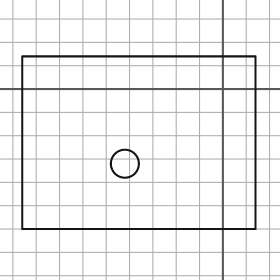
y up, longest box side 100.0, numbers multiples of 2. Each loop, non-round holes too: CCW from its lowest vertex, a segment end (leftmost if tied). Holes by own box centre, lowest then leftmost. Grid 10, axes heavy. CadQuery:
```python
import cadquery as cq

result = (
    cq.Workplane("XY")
    .moveTo(-86.0, -60.0)
    .lineTo(14.0, -60.0)
    .lineTo(14.0, 14.0)
    .lineTo(-86.0, 14.0)
    .close()
    .moveTo(-42.0, -32.0)
    .circle(6.0)
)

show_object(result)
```